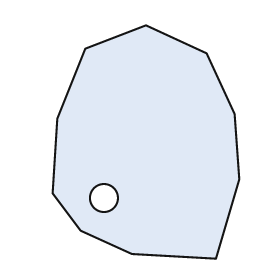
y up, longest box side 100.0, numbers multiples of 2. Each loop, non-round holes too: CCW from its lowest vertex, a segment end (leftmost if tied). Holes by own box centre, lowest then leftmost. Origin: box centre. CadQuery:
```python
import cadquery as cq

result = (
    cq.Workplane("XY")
    .moveTo(30.0, -50.0)
    .lineTo(40.0, -16.0)
    .lineTo(38.0, 12.0)
    .lineTo(26.0, 38.0)
    .lineTo(0.0, 50.0)
    .lineTo(-26.0, 40.0)
    .lineTo(-38.0, 10.0)
    .lineTo(-40.0, -22.0)
    .lineTo(-28.0, -38.0)
    .lineTo(-6.0, -48.0)
    .close()
    .moveTo(-18.0, -24.0)
    .circle(6.0)
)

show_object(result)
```